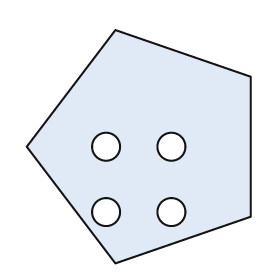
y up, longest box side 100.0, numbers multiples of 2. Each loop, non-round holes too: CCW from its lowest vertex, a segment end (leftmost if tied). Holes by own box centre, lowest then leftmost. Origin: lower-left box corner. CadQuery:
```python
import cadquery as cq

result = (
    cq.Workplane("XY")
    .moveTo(38.0, 0.0)
    .lineTo(96.0, 20.0)
    .lineTo(96.0, 80.0)
    .lineTo(38.0, 100.0)
    .lineTo(0.0, 50.0)
    .close()
    .moveTo(34.0, 22.0)
    .circle(6.0)
    .moveTo(62.0, 22.0)
    .circle(6.0)
    .moveTo(34.0, 50.0)
    .circle(6.0)
    .moveTo(62.0, 50.0)
    .circle(6.0)
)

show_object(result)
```